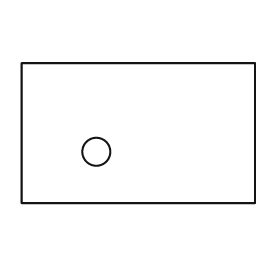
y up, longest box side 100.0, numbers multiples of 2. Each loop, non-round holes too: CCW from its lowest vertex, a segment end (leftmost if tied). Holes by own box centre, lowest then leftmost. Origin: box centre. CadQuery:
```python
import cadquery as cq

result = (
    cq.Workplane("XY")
    .moveTo(-50.0, -30.0)
    .lineTo(50.0, -30.0)
    .lineTo(50.0, 30.0)
    .lineTo(-50.0, 30.0)
    .close()
    .moveTo(-18.0, -8.0)
    .circle(6.0)
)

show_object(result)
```